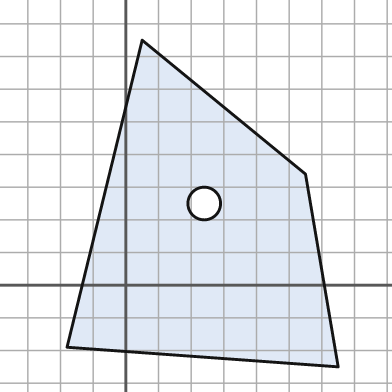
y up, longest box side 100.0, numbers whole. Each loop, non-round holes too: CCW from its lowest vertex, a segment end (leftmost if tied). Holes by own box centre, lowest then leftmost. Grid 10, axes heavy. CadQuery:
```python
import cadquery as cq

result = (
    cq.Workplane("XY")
    .moveTo(65.0, -25.0)
    .lineTo(55.0, 34.0)
    .lineTo(5.0, 75.0)
    .lineTo(-18.0, -19.0)
    .close()
    .moveTo(24.0, 25.0)
    .circle(5.0)
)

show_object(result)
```